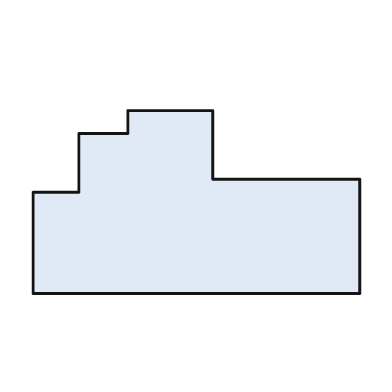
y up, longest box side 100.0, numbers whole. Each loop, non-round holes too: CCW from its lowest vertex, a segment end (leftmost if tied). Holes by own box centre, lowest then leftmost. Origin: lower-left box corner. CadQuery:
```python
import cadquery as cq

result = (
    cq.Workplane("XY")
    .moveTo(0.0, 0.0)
    .lineTo(100.0, 0.0)
    .lineTo(100.0, 35.0)
    .lineTo(55.0, 35.0)
    .lineTo(55.0, 56.0)
    .lineTo(29.0, 56.0)
    .lineTo(29.0, 49.0)
    .lineTo(14.0, 49.0)
    .lineTo(14.0, 31.0)
    .lineTo(0.0, 31.0)
    .close()
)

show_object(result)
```